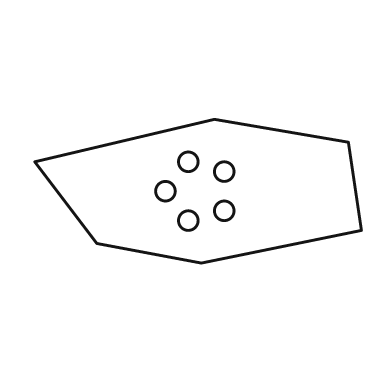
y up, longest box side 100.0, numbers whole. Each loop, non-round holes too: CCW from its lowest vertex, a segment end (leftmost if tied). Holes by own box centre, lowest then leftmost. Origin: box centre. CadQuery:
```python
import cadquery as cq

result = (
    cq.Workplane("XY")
    .moveTo(1.0, -22.0)
    .lineTo(50.0, -12.0)
    .lineTo(46.0, 15.0)
    .lineTo(5.0, 22.0)
    .lineTo(-50.0, 9.0)
    .lineTo(-31.0, -16.0)
    .close()
    .moveTo(-3.0, -9.0)
    .circle(3.0)
    .moveTo(8.0, -6.0)
    .circle(3.0)
    .moveTo(-10.0, 0.0)
    .circle(3.0)
    .moveTo(8.0, 6.0)
    .circle(3.0)
    .moveTo(-3.0, 9.0)
    .circle(3.0)
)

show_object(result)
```